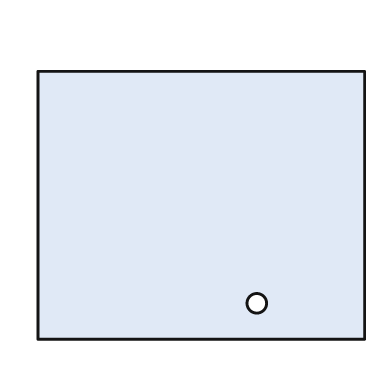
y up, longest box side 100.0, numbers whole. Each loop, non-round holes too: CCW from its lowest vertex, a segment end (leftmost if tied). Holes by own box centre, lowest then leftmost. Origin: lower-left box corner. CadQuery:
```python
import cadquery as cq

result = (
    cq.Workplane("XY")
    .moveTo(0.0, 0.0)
    .lineTo(100.0, 0.0)
    .lineTo(100.0, 82.0)
    .lineTo(0.0, 82.0)
    .close()
    .moveTo(67.0, 11.0)
    .circle(3.0)
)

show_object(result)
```